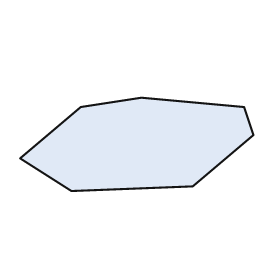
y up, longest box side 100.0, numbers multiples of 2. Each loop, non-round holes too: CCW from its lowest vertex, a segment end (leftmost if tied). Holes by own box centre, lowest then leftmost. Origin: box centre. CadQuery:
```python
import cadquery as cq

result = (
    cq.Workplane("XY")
    .moveTo(-28.0, -20.0)
    .lineTo(24.0, -18.0)
    .lineTo(50.0, 4.0)
    .lineTo(46.0, 16.0)
    .lineTo(2.0, 20.0)
    .lineTo(-24.0, 16.0)
    .lineTo(-50.0, -6.0)
    .close()
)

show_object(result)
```